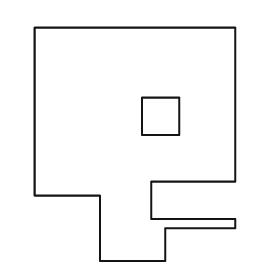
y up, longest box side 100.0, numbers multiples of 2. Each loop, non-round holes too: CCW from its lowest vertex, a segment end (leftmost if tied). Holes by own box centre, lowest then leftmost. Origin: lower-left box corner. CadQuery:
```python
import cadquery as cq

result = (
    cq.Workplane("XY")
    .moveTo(28.0, 0.0)
    .lineTo(56.0, 0.0)
    .lineTo(56.0, 14.0)
    .lineTo(86.0, 14.0)
    .lineTo(86.0, 18.0)
    .lineTo(50.0, 18.0)
    .lineTo(50.0, 34.0)
    .lineTo(86.0, 34.0)
    .lineTo(86.0, 100.0)
    .lineTo(0.0, 100.0)
    .lineTo(0.0, 28.0)
    .lineTo(28.0, 28.0)
    .close()
    .moveTo(46.0, 54.0)
    .lineTo(62.0, 54.0)
    .lineTo(62.0, 70.0)
    .lineTo(46.0, 70.0)
    .close()
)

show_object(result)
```